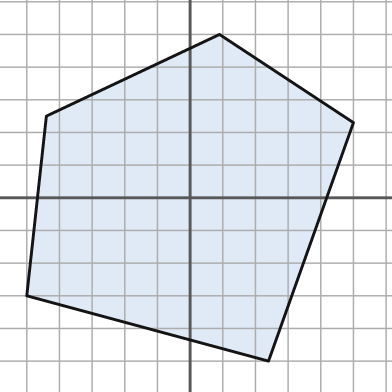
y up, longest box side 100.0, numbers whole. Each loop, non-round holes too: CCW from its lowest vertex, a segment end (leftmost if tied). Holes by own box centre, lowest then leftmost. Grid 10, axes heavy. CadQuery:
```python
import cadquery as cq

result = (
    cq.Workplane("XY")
    .moveTo(24.0, -50.0)
    .lineTo(50.0, 23.0)
    .lineTo(9.0, 50.0)
    .lineTo(-44.0, 25.0)
    .lineTo(-50.0, -30.0)
    .close()
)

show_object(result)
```